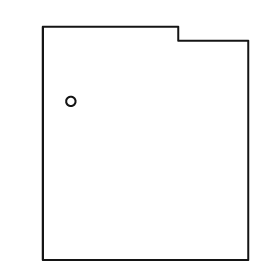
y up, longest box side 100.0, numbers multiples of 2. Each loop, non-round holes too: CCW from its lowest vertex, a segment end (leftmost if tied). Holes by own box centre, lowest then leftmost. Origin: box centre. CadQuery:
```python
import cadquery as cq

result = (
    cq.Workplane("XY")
    .moveTo(-44.0, -50.0)
    .lineTo(44.0, -50.0)
    .lineTo(44.0, 44.0)
    .lineTo(14.0, 44.0)
    .lineTo(14.0, 50.0)
    .lineTo(-44.0, 50.0)
    .close()
    .moveTo(-32.0, 18.0)
    .circle(2.0)
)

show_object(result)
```